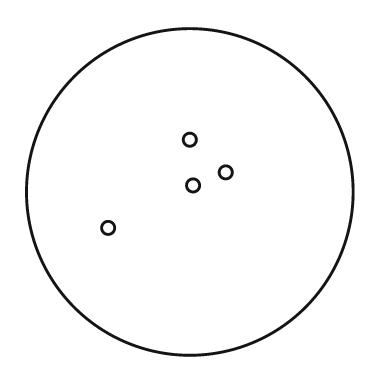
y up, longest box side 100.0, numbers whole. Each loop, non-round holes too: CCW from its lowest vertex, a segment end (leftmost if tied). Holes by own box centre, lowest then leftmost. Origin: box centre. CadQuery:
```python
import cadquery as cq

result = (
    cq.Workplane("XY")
    .moveTo(0.0, 0.0)
    .circle(50.0)
    .moveTo(-25.0, -11.0)
    .circle(2.0)
    .moveTo(1.0, 2.0)
    .circle(2.0)
    .moveTo(11.0, 6.0)
    .circle(2.0)
    .moveTo(0.0, 16.0)
    .circle(2.0)
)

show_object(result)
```